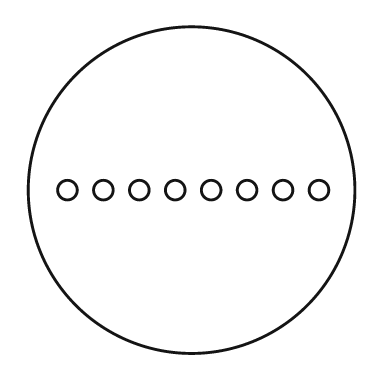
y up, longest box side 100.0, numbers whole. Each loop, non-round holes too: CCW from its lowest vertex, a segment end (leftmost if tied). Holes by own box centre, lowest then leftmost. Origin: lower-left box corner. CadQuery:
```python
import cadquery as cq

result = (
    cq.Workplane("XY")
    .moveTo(50.0, 50.0)
    .circle(50.0)
    .moveTo(12.0, 50.0)
    .circle(3.0)
    .moveTo(23.0, 50.0)
    .circle(3.0)
    .moveTo(34.0, 50.0)
    .circle(3.0)
    .moveTo(45.0, 50.0)
    .circle(3.0)
    .moveTo(56.0, 50.0)
    .circle(3.0)
    .moveTo(67.0, 50.0)
    .circle(3.0)
    .moveTo(78.0, 50.0)
    .circle(3.0)
    .moveTo(89.0, 50.0)
    .circle(3.0)
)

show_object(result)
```